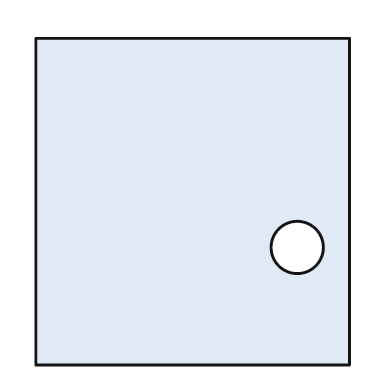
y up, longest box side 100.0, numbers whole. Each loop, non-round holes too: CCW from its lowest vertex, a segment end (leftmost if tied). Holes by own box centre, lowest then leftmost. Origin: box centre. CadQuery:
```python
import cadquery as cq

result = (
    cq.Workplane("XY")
    .moveTo(-48.0, -50.0)
    .lineTo(48.0, -50.0)
    .lineTo(48.0, 50.0)
    .lineTo(-48.0, 50.0)
    .close()
    .moveTo(32.0, -14.0)
    .circle(8.0)
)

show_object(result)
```